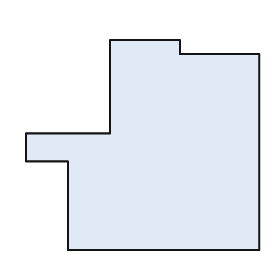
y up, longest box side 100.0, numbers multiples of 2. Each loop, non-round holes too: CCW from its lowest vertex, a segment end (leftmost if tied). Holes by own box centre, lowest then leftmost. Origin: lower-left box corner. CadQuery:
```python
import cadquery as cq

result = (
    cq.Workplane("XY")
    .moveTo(18.0, 0.0)
    .lineTo(100.0, 0.0)
    .lineTo(100.0, 84.0)
    .lineTo(66.0, 84.0)
    .lineTo(66.0, 90.0)
    .lineTo(36.0, 90.0)
    .lineTo(36.0, 50.0)
    .lineTo(0.0, 50.0)
    .lineTo(0.0, 38.0)
    .lineTo(18.0, 38.0)
    .close()
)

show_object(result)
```